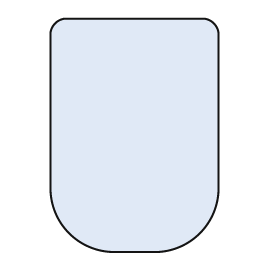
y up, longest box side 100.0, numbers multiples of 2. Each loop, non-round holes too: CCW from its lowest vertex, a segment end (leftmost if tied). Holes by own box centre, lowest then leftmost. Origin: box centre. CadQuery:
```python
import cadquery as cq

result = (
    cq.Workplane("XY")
    .moveTo(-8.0, -50.0)
    .lineTo(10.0, -50.0)
    .threePointArc((28.0, -42.0), (36.0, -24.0))
    .lineTo(36.0, 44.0)
    .threePointArc((34.0, 48.0), (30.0, 50.0))
    .lineTo(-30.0, 50.0)
    .threePointArc((-34.0, 48.0), (-36.0, 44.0))
    .lineTo(-36.0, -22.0)
    .threePointArc((-28.0, -42.0), (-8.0, -50.0))
    .close()
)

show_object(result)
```